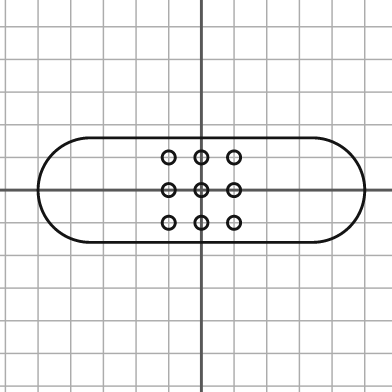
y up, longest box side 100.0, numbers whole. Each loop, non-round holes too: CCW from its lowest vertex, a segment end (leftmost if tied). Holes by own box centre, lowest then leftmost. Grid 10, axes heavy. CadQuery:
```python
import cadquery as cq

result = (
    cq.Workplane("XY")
    .moveTo(-34.0, -16.0)
    .lineTo(34.0, -16.0)
    .threePointArc((50.0, 0.0), (34.0, 16.0))
    .lineTo(-34.0, 16.0)
    .threePointArc((-50.0, 0.0), (-34.0, -16.0))
    .close()
    .moveTo(-10.0, -10.0)
    .circle(2.0)
    .moveTo(0.0, -10.0)
    .circle(2.0)
    .moveTo(10.0, -10.0)
    .circle(2.0)
    .moveTo(-10.0, 0.0)
    .circle(2.0)
    .moveTo(0.0, 0.0)
    .circle(2.0)
    .moveTo(10.0, 0.0)
    .circle(2.0)
    .moveTo(-10.0, 10.0)
    .circle(2.0)
    .moveTo(0.0, 10.0)
    .circle(2.0)
    .moveTo(10.0, 10.0)
    .circle(2.0)
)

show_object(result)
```